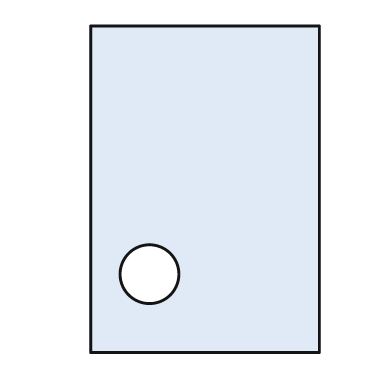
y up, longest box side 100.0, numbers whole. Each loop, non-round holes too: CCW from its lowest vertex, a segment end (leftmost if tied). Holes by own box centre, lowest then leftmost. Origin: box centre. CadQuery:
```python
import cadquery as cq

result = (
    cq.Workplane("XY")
    .moveTo(-35.0, -50.0)
    .lineTo(35.0, -50.0)
    .lineTo(35.0, 50.0)
    .lineTo(-35.0, 50.0)
    .close()
    .moveTo(-17.0, -26.0)
    .circle(9.0)
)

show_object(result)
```